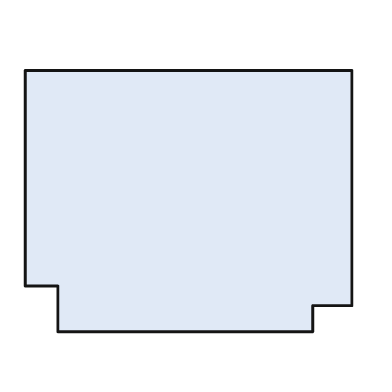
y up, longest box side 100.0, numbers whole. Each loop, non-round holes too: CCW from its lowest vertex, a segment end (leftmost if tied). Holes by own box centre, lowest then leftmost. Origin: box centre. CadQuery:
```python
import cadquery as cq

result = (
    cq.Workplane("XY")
    .moveTo(-40.0, -40.0)
    .lineTo(38.0, -40.0)
    .lineTo(38.0, -32.0)
    .lineTo(50.0, -32.0)
    .lineTo(50.0, 40.0)
    .lineTo(-50.0, 40.0)
    .lineTo(-50.0, -26.0)
    .lineTo(-40.0, -26.0)
    .close()
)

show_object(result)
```